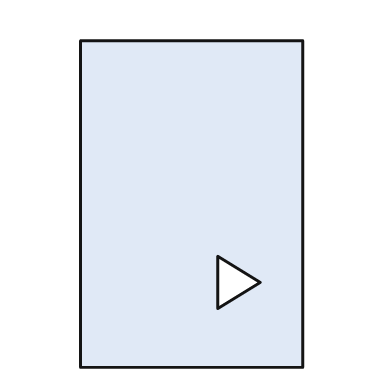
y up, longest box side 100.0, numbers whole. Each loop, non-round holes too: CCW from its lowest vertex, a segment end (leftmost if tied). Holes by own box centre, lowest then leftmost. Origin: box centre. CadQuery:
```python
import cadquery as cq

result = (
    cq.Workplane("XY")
    .moveTo(-34.0, -50.0)
    .lineTo(34.0, -50.0)
    .lineTo(34.0, 50.0)
    .lineTo(-34.0, 50.0)
    .close()
    .moveTo(8.0, -32.0)
    .lineTo(21.0, -24.0)
    .lineTo(8.0, -16.0)
    .close()
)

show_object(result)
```